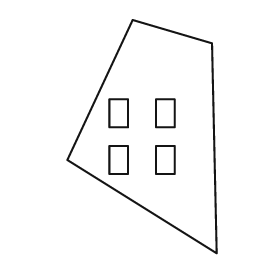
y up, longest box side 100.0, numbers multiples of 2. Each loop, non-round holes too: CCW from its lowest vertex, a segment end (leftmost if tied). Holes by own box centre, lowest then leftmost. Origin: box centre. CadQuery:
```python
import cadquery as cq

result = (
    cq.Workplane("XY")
    .moveTo(32.0, -50.0)
    .lineTo(30.0, 40.0)
    .lineTo(-4.0, 50.0)
    .lineTo(-32.0, -10.0)
    .close()
    .moveTo(-14.0, -16.0)
    .lineTo(-6.0, -16.0)
    .lineTo(-6.0, -4.0)
    .lineTo(-14.0, -4.0)
    .close()
    .moveTo(6.0, -16.0)
    .lineTo(14.0, -16.0)
    .lineTo(14.0, -4.0)
    .lineTo(6.0, -4.0)
    .close()
    .moveTo(-14.0, 4.0)
    .lineTo(-6.0, 4.0)
    .lineTo(-6.0, 16.0)
    .lineTo(-14.0, 16.0)
    .close()
    .moveTo(6.0, 4.0)
    .lineTo(14.0, 4.0)
    .lineTo(14.0, 16.0)
    .lineTo(6.0, 16.0)
    .close()
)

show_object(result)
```